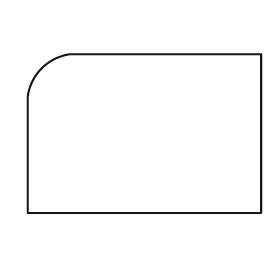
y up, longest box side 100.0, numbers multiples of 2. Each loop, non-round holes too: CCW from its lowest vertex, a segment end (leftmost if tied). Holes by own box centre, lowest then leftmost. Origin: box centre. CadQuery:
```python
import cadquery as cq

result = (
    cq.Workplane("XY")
    .moveTo(-50.0, -34.0)
    .lineTo(50.0, -34.0)
    .lineTo(50.0, 34.0)
    .lineTo(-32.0, 34.0)
    .threePointArc((-44.0, 28.0), (-50.0, 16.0))
    .close()
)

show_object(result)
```